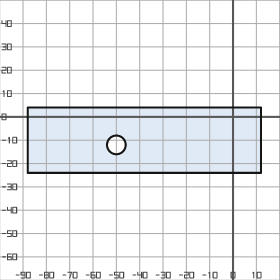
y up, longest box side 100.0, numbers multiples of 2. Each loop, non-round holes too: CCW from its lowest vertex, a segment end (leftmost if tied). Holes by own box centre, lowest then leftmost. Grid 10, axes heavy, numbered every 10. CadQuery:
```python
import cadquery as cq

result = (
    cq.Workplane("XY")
    .moveTo(-88.0, -24.0)
    .lineTo(12.0, -24.0)
    .lineTo(12.0, 4.0)
    .lineTo(-88.0, 4.0)
    .close()
    .moveTo(-50.0, -12.0)
    .circle(4.0)
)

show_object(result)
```